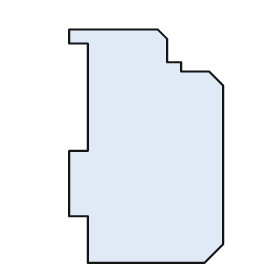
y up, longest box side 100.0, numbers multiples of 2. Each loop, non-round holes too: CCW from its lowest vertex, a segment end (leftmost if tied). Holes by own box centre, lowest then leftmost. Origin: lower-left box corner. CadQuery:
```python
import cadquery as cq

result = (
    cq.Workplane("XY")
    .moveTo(8.0, 0.0)
    .lineTo(58.0, 0.0)
    .lineTo(66.0, 8.0)
    .lineTo(66.0, 76.0)
    .lineTo(60.0, 82.0)
    .lineTo(48.0, 82.0)
    .lineTo(48.0, 86.0)
    .lineTo(42.0, 86.0)
    .lineTo(42.0, 96.0)
    .lineTo(38.0, 100.0)
    .lineTo(0.0, 100.0)
    .lineTo(0.0, 94.0)
    .lineTo(8.0, 94.0)
    .lineTo(8.0, 48.0)
    .lineTo(0.0, 48.0)
    .lineTo(0.0, 20.0)
    .lineTo(8.0, 20.0)
    .close()
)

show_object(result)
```